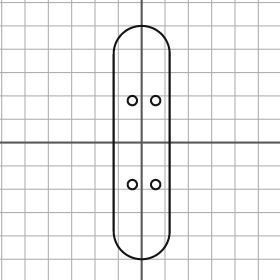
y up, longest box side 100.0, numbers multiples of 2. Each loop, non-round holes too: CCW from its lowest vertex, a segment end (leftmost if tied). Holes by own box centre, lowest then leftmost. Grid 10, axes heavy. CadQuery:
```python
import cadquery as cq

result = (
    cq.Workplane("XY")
    .moveTo(-12.0, -38.0)
    .threePointArc((0.0, -50.0), (12.0, -38.0))
    .lineTo(12.0, 38.0)
    .threePointArc((0.0, 50.0), (-12.0, 38.0))
    .close()
    .moveTo(-4.0, -18.0)
    .circle(2.0)
    .moveTo(6.0, -18.0)
    .circle(2.0)
    .moveTo(-4.0, 18.0)
    .circle(2.0)
    .moveTo(6.0, 18.0)
    .circle(2.0)
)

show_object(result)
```